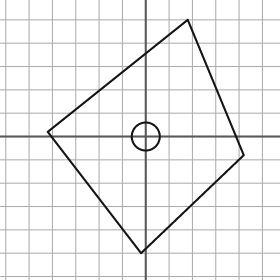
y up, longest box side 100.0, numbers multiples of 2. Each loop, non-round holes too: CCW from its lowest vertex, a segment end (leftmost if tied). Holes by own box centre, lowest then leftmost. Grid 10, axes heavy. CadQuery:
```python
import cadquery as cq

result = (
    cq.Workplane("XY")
    .moveTo(-2.0, -50.0)
    .lineTo(42.0, -8.0)
    .lineTo(18.0, 50.0)
    .lineTo(-42.0, 2.0)
    .close()
    .moveTo(0.0, 0.0)
    .circle(6.0)
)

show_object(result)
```